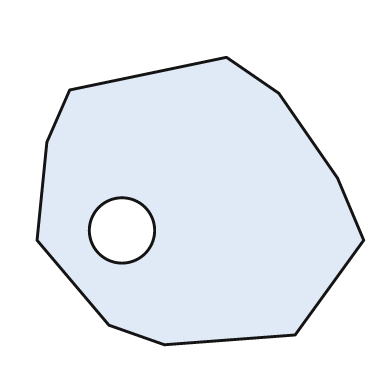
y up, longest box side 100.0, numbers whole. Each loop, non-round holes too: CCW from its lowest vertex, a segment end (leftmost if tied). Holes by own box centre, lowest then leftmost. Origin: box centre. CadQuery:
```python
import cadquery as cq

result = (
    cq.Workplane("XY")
    .moveTo(-11.0, -44.0)
    .lineTo(29.0, -41.0)
    .lineTo(50.0, -12.0)
    .lineTo(42.0, 7.0)
    .lineTo(24.0, 33.0)
    .lineTo(8.0, 44.0)
    .lineTo(-40.0, 34.0)
    .lineTo(-47.0, 18.0)
    .lineTo(-50.0, -12.0)
    .lineTo(-28.0, -38.0)
    .close()
    .moveTo(-24.0, -9.0)
    .circle(10.0)
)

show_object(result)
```